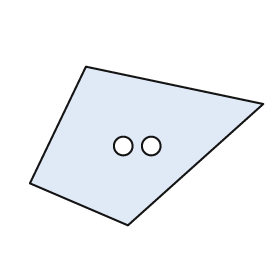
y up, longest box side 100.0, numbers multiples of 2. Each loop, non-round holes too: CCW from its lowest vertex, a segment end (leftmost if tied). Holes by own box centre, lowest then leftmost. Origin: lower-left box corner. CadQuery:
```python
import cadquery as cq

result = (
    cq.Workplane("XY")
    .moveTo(42.0, 0.0)
    .lineTo(100.0, 52.0)
    .lineTo(24.0, 68.0)
    .lineTo(0.0, 18.0)
    .close()
    .moveTo(40.0, 34.0)
    .circle(4.0)
    .moveTo(52.0, 34.0)
    .circle(4.0)
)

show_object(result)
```